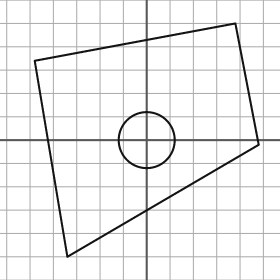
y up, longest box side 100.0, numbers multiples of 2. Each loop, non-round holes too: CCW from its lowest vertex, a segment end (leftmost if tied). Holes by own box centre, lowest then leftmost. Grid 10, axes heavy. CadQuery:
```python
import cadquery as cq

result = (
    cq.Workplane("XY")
    .moveTo(-34.0, -50.0)
    .lineTo(48.0, -2.0)
    .lineTo(38.0, 50.0)
    .lineTo(-48.0, 34.0)
    .close()
    .moveTo(0.0, 0.0)
    .circle(12.0)
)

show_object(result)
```